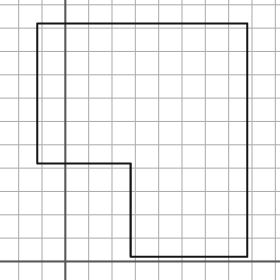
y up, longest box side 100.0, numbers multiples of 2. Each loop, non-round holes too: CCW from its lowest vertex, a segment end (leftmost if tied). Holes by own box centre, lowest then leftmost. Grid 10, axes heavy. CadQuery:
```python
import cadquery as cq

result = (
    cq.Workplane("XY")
    .moveTo(28.0, 2.0)
    .lineTo(78.0, 2.0)
    .lineTo(78.0, 102.0)
    .lineTo(-12.0, 102.0)
    .lineTo(-12.0, 42.0)
    .lineTo(28.0, 42.0)
    .close()
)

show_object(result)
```